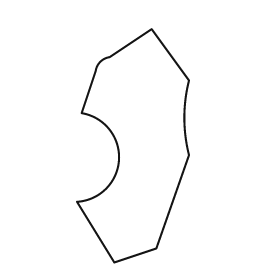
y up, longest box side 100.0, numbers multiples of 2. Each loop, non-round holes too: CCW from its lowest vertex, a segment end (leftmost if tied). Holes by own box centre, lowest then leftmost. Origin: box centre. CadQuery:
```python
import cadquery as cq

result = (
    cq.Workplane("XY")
    .moveTo(-8.0, -50.0)
    .lineTo(10.0, -44.0)
    .lineTo(24.0, -4.0)
    .threePointArc((22.0, 12.0), (24.0, 28.0))
    .lineTo(8.0, 50.0)
    .lineTo(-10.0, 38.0)
    .threePointArc((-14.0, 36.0), (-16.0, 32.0))
    .lineTo(-22.0, 14.0)
    .threePointArc((-6.0, -6.0), (-24.0, -24.0))
    .close()
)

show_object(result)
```